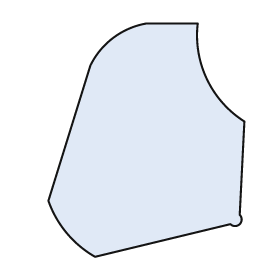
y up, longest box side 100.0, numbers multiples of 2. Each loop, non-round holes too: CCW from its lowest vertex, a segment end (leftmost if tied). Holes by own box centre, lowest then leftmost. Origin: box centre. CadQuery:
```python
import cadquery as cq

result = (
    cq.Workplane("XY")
    .moveTo(-22.0, -50.0)
    .lineTo(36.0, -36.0)
    .threePointArc((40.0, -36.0), (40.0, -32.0))
    .lineTo(42.0, 8.0)
    .threePointArc((26.0, 26.0), (22.0, 50.0))
    .lineTo(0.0, 50.0)
    .threePointArc((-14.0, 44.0), (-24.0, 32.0))
    .lineTo(-42.0, -26.0)
    .threePointArc((-34.0, -40.0), (-22.0, -50.0))
    .close()
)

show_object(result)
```